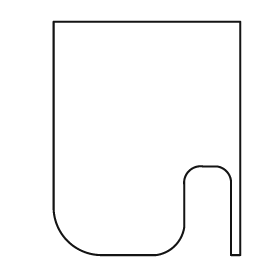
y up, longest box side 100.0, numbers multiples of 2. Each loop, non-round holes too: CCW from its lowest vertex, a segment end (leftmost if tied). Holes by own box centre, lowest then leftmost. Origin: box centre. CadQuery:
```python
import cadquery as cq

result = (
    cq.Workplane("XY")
    .moveTo(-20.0, -50.0)
    .lineTo(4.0, -50.0)
    .threePointArc((12.0, -46.0), (16.0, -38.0))
    .lineTo(16.0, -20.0)
    .threePointArc((18.0, -14.0), (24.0, -12.0))
    .lineTo(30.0, -12.0)
    .threePointArc((34.0, -14.0), (36.0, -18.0))
    .lineTo(36.0, -50.0)
    .lineTo(40.0, -50.0)
    .lineTo(40.0, 50.0)
    .lineTo(-40.0, 50.0)
    .lineTo(-40.0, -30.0)
    .threePointArc((-34.0, -44.0), (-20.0, -50.0))
    .close()
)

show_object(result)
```